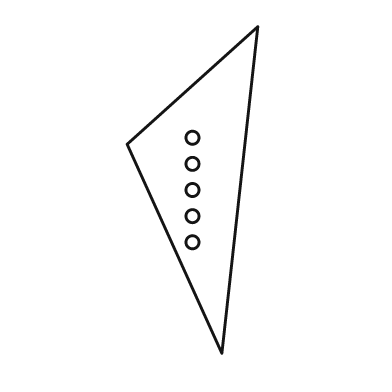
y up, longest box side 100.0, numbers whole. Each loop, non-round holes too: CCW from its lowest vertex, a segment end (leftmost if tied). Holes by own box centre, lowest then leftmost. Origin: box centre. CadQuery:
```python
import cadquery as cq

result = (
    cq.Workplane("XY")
    .moveTo(9.0, -50.0)
    .lineTo(20.0, 50.0)
    .lineTo(-20.0, 14.0)
    .close()
    .moveTo(0.0, -16.0)
    .circle(2.0)
    .moveTo(0.0, -8.0)
    .circle(2.0)
    .moveTo(0.0, 0.0)
    .circle(2.0)
    .moveTo(0.0, 8.0)
    .circle(2.0)
    .moveTo(0.0, 16.0)
    .circle(2.0)
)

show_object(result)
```